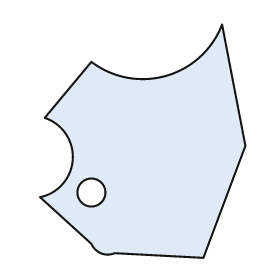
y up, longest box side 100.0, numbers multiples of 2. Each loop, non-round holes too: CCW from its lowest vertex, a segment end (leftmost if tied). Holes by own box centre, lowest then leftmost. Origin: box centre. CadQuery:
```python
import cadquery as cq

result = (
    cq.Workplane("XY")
    .moveTo(26.0, -50.0)
    .lineTo(44.0, -2.0)
    .lineTo(34.0, 50.0)
    .threePointArc((10.0, 28.0), (-22.0, 34.0))
    .lineTo(-42.0, 10.0)
    .threePointArc((-30.0, -8.0), (-44.0, -24.0))
    .lineTo(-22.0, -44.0)
    .threePointArc((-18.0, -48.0), (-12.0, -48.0))
    .close()
    .moveTo(-22.0, -22.0)
    .circle(6.0)
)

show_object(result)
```